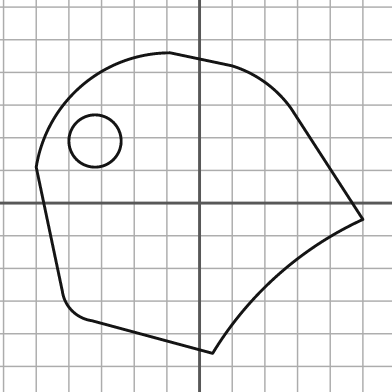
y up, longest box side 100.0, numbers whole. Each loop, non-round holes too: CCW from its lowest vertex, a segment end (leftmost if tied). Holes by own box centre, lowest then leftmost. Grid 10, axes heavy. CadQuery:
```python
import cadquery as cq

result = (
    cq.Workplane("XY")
    .moveTo(4.0, -46.0)
    .threePointArc((24.0, -22.0), (50.0, -5.0))
    .lineTo(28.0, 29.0)
    .threePointArc((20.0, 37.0), (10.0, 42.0))
    .lineTo(-9.0, 46.0)
    .threePointArc((-36.0, 36.0), (-50.0, 11.0))
    .lineTo(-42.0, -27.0)
    .threePointArc((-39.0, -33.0), (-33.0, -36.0))
    .close()
    .moveTo(-32.0, 19.0)
    .circle(8.0)
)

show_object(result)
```